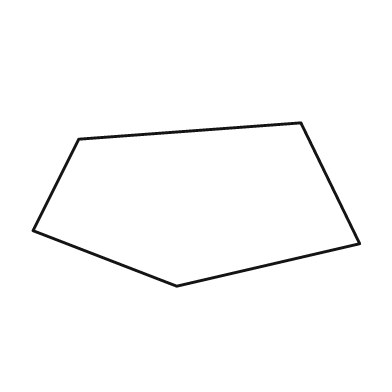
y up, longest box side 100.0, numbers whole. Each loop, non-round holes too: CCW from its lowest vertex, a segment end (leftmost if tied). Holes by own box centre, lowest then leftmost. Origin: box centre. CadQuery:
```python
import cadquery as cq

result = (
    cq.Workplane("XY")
    .moveTo(-6.0, -25.0)
    .lineTo(50.0, -12.0)
    .lineTo(32.0, 25.0)
    .lineTo(-36.0, 20.0)
    .lineTo(-50.0, -8.0)
    .close()
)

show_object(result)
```